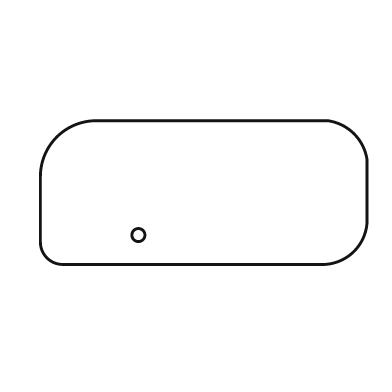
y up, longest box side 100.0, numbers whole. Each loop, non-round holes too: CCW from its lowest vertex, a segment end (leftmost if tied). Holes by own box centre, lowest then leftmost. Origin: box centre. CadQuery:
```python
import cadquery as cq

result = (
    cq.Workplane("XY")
    .moveTo(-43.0, -22.0)
    .lineTo(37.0, -22.0)
    .threePointArc((46.0, -18.0), (50.0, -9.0))
    .lineTo(50.0, 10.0)
    .threePointArc((46.0, 18.0), (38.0, 22.0))
    .lineTo(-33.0, 22.0)
    .threePointArc((-45.0, 17.0), (-50.0, 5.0))
    .lineTo(-50.0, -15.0)
    .threePointArc((-48.0, -20.0), (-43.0, -22.0))
    .close()
    .moveTo(-20.0, -13.0)
    .circle(2.0)
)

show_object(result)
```